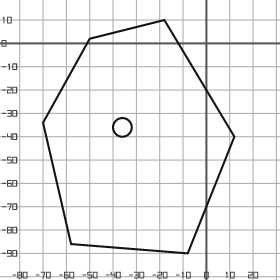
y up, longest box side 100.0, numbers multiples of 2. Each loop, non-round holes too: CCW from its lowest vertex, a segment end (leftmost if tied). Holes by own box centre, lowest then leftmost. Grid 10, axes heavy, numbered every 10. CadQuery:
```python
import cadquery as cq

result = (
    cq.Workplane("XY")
    .moveTo(-8.0, -90.0)
    .lineTo(12.0, -40.0)
    .lineTo(-18.0, 10.0)
    .lineTo(-50.0, 2.0)
    .lineTo(-70.0, -34.0)
    .lineTo(-58.0, -86.0)
    .close()
    .moveTo(-36.0, -36.0)
    .circle(4.0)
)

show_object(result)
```